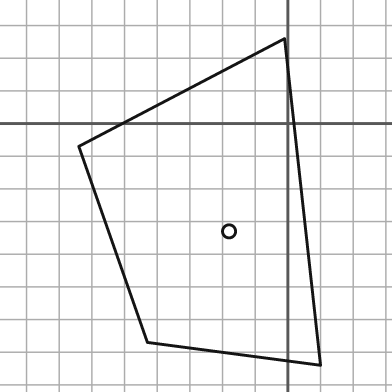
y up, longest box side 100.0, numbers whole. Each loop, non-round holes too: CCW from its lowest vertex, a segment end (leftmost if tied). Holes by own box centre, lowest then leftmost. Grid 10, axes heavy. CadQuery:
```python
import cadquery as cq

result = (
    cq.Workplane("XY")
    .moveTo(10.0, -74.0)
    .lineTo(-1.0, 26.0)
    .lineTo(-64.0, -7.0)
    .lineTo(-43.0, -67.0)
    .close()
    .moveTo(-18.0, -33.0)
    .circle(2.0)
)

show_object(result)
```